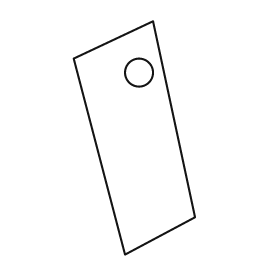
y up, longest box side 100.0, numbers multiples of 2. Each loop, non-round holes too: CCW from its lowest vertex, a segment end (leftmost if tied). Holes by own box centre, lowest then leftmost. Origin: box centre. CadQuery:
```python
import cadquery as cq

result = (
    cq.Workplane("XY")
    .moveTo(-4.0, -50.0)
    .lineTo(26.0, -34.0)
    .lineTo(8.0, 50.0)
    .lineTo(-26.0, 34.0)
    .close()
    .moveTo(2.0, 28.0)
    .circle(6.0)
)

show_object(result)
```